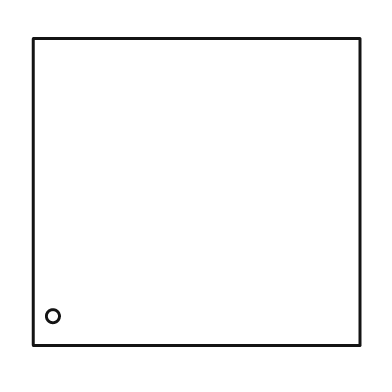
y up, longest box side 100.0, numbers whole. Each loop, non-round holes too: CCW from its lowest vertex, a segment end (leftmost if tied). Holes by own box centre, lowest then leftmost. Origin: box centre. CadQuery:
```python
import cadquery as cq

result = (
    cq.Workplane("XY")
    .moveTo(-50.0, -47.0)
    .lineTo(50.0, -47.0)
    .lineTo(50.0, 47.0)
    .lineTo(-50.0, 47.0)
    .close()
    .moveTo(-44.0, -38.0)
    .circle(2.0)
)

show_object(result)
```